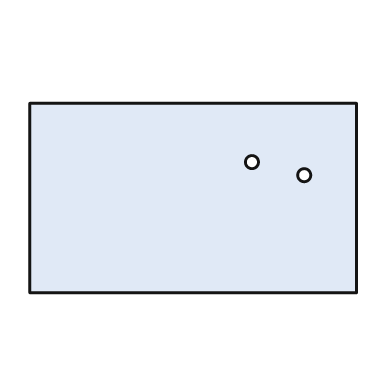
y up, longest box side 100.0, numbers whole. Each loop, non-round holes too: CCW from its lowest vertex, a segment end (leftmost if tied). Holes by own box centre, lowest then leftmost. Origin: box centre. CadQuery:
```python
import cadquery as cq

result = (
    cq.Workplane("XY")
    .moveTo(-50.0, -29.0)
    .lineTo(50.0, -29.0)
    .lineTo(50.0, 29.0)
    .lineTo(-50.0, 29.0)
    .close()
    .moveTo(34.0, 7.0)
    .circle(2.0)
    .moveTo(18.0, 11.0)
    .circle(2.0)
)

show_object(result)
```